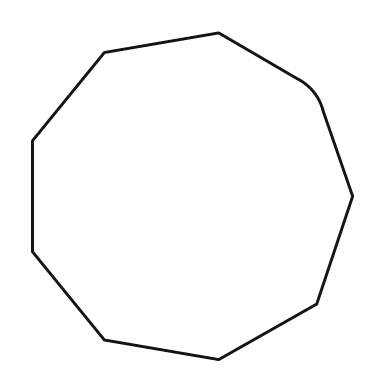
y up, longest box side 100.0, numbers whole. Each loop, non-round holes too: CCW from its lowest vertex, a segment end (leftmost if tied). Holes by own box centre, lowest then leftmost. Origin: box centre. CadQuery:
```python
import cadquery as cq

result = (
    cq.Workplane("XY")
    .moveTo(8.0, -50.0)
    .lineTo(38.0, -33.0)
    .lineTo(49.0, 0.0)
    .lineTo(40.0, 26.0)
    .threePointArc((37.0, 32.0), (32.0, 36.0))
    .lineTo(8.0, 50.0)
    .lineTo(-27.0, 44.0)
    .lineTo(-49.0, 17.0)
    .lineTo(-49.0, -17.0)
    .lineTo(-27.0, -44.0)
    .close()
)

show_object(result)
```